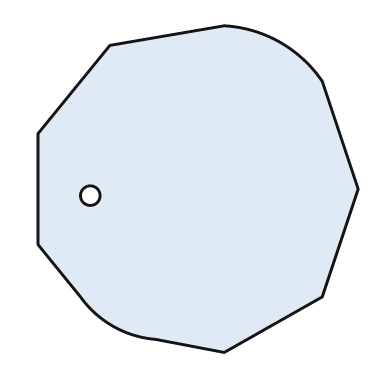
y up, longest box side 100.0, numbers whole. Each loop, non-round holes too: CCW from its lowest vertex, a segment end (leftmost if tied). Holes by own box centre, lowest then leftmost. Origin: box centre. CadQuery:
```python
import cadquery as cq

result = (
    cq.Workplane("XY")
    .moveTo(8.0, -50.0)
    .lineTo(38.0, -33.0)
    .lineTo(49.0, 0.0)
    .lineTo(38.0, 33.0)
    .threePointArc((25.0, 45.0), (8.0, 50.0))
    .lineTo(-27.0, 44.0)
    .lineTo(-49.0, 17.0)
    .lineTo(-49.0, -17.0)
    .lineTo(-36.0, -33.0)
    .threePointArc((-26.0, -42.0), (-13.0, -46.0))
    .close()
    .moveTo(-33.0, -2.0)
    .circle(3.0)
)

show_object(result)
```